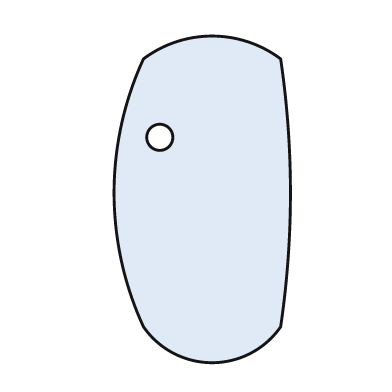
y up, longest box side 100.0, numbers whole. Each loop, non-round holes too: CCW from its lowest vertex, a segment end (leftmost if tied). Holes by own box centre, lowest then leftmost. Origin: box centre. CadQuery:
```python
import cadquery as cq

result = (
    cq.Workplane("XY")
    .moveTo(-18.0, -39.0)
    .threePointArc((3.0, -50.0), (24.0, -39.0))
    .threePointArc((27.0, 2.0), (24.0, 43.0))
    .threePointArc((3.0, 50.0), (-18.0, 43.0))
    .threePointArc((-27.0, 2.0), (-18.0, -39.0))
    .close()
    .moveTo(-13.0, 19.0)
    .circle(4.0)
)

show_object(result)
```